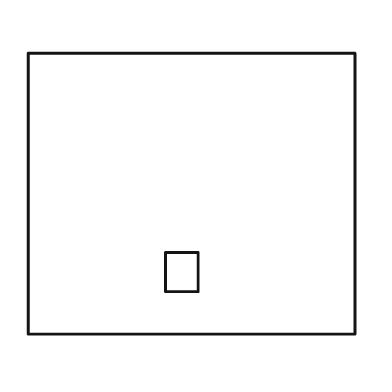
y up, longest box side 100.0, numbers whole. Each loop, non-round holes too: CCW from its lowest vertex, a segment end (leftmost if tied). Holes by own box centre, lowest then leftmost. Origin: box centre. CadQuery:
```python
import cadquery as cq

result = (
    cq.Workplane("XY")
    .moveTo(-50.0, -43.0)
    .lineTo(50.0, -43.0)
    .lineTo(50.0, 43.0)
    .lineTo(-50.0, 43.0)
    .close()
    .moveTo(-8.0, -30.0)
    .lineTo(2.0, -30.0)
    .lineTo(2.0, -18.0)
    .lineTo(-8.0, -18.0)
    .close()
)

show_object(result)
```